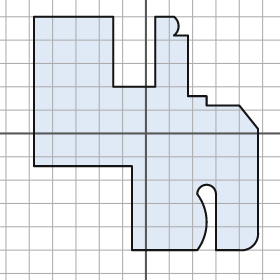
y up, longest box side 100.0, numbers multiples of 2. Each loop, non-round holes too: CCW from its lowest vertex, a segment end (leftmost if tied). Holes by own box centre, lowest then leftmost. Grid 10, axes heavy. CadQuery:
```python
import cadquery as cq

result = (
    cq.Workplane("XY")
    .moveTo(-6.0, -50.0)
    .lineTo(22.0, -50.0)
    .threePointArc((26.0, -38.0), (22.0, -26.0))
    .threePointArc((26.0, -22.0), (30.0, -26.0))
    .lineTo(30.0, -50.0)
    .lineTo(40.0, -50.0)
    .threePointArc((46.0, -48.0), (48.0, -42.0))
    .lineTo(48.0, 2.0)
    .lineTo(40.0, 12.0)
    .lineTo(26.0, 12.0)
    .lineTo(26.0, 16.0)
    .lineTo(18.0, 16.0)
    .lineTo(18.0, 42.0)
    .lineTo(12.0, 42.0)
    .threePointArc((14.0, 46.0), (12.0, 50.0))
    .lineTo(4.0, 50.0)
    .lineTo(4.0, 20.0)
    .lineTo(-14.0, 20.0)
    .lineTo(-14.0, 50.0)
    .lineTo(-48.0, 50.0)
    .lineTo(-48.0, -14.0)
    .lineTo(-6.0, -14.0)
    .close()
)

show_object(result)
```